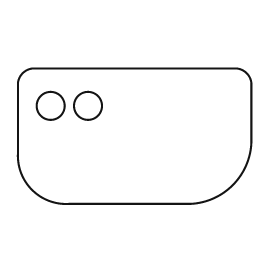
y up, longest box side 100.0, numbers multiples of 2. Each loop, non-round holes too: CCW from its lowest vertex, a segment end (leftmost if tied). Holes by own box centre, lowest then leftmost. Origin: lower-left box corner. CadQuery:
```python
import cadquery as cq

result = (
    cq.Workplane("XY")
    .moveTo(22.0, 0.0)
    .lineTo(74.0, 0.0)
    .threePointArc((92.0, 8.0), (100.0, 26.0))
    .lineTo(100.0, 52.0)
    .threePointArc((98.0, 56.0), (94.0, 58.0))
    .lineTo(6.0, 58.0)
    .threePointArc((2.0, 56.0), (0.0, 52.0))
    .lineTo(0.0, 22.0)
    .threePointArc((6.0, 6.0), (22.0, 0.0))
    .close()
    .moveTo(14.0, 42.0)
    .circle(6.0)
    .moveTo(30.0, 42.0)
    .circle(6.0)
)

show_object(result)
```